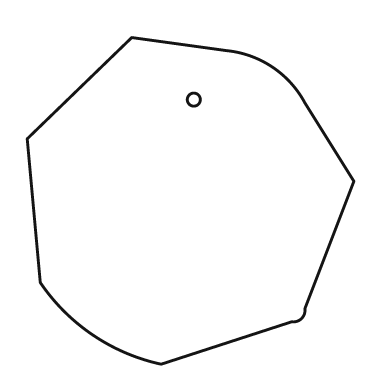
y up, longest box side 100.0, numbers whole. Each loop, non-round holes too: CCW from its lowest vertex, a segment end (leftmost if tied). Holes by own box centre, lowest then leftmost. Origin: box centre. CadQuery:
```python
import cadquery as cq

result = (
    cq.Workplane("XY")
    .moveTo(-9.0, -50.0)
    .lineTo(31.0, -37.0)
    .threePointArc((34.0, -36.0), (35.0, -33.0))
    .lineTo(50.0, 6.0)
    .lineTo(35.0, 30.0)
    .threePointArc((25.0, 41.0), (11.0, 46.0))
    .lineTo(-18.0, 50.0)
    .lineTo(-50.0, 19.0)
    .lineTo(-46.0, -25.0)
    .threePointArc((-30.0, -41.0), (-9.0, -50.0))
    .close()
    .moveTo(1.0, 31.0)
    .circle(2.0)
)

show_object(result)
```